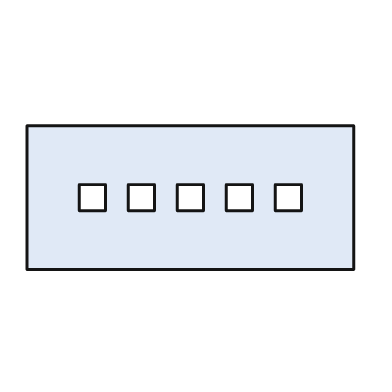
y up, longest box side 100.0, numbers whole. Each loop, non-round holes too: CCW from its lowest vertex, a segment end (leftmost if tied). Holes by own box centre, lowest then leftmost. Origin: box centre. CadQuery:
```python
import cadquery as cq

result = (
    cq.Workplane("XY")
    .moveTo(-50.0, -22.0)
    .lineTo(50.0, -22.0)
    .lineTo(50.0, 22.0)
    .lineTo(-50.0, 22.0)
    .close()
    .moveTo(-34.0, -4.0)
    .lineTo(-26.0, -4.0)
    .lineTo(-26.0, 4.0)
    .lineTo(-34.0, 4.0)
    .close()
    .moveTo(-19.0, -4.0)
    .lineTo(-11.0, -4.0)
    .lineTo(-11.0, 4.0)
    .lineTo(-19.0, 4.0)
    .close()
    .moveTo(-4.0, -4.0)
    .lineTo(4.0, -4.0)
    .lineTo(4.0, 4.0)
    .lineTo(-4.0, 4.0)
    .close()
    .moveTo(11.0, -4.0)
    .lineTo(19.0, -4.0)
    .lineTo(19.0, 4.0)
    .lineTo(11.0, 4.0)
    .close()
    .moveTo(26.0, -4.0)
    .lineTo(34.0, -4.0)
    .lineTo(34.0, 4.0)
    .lineTo(26.0, 4.0)
    .close()
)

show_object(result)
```